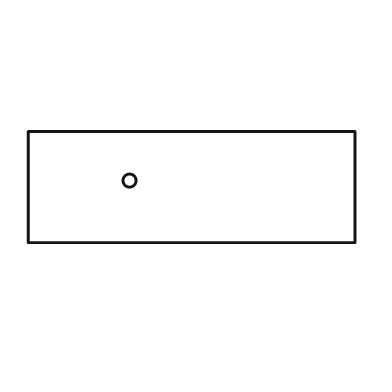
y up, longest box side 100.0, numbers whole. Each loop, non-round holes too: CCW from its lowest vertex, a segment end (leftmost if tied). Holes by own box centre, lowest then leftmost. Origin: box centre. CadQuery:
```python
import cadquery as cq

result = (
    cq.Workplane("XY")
    .moveTo(-50.0, -17.0)
    .lineTo(50.0, -17.0)
    .lineTo(50.0, 17.0)
    .lineTo(-50.0, 17.0)
    .close()
    .moveTo(-19.0, 2.0)
    .circle(2.0)
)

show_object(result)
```